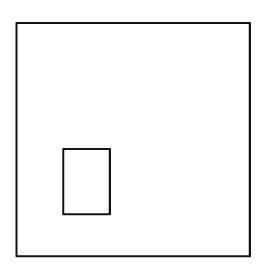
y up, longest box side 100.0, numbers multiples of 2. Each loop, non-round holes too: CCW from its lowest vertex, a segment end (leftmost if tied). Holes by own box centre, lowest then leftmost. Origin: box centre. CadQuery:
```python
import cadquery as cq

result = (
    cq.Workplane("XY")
    .moveTo(-50.0, -50.0)
    .lineTo(50.0, -50.0)
    .lineTo(50.0, 50.0)
    .lineTo(-50.0, 50.0)
    .close()
    .moveTo(-30.0, -32.0)
    .lineTo(-10.0, -32.0)
    .lineTo(-10.0, -4.0)
    .lineTo(-30.0, -4.0)
    .close()
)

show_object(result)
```